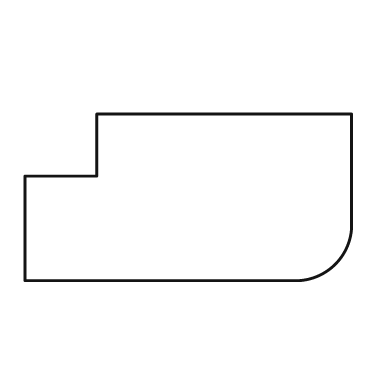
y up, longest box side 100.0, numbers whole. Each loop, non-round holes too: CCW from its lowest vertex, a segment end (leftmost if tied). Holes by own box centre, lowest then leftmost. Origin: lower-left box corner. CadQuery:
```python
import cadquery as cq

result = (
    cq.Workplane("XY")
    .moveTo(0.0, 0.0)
    .lineTo(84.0, 0.0)
    .threePointArc((95.0, 5.0), (100.0, 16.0))
    .lineTo(100.0, 51.0)
    .lineTo(22.0, 51.0)
    .lineTo(22.0, 32.0)
    .lineTo(0.0, 32.0)
    .close()
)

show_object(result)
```